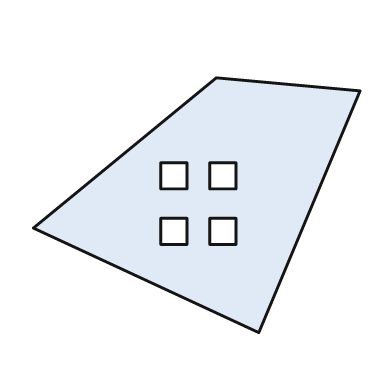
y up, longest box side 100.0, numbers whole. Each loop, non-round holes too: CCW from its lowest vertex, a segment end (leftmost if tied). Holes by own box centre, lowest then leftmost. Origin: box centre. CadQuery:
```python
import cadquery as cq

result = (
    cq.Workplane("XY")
    .moveTo(19.0, -39.0)
    .lineTo(50.0, 35.0)
    .lineTo(6.0, 39.0)
    .lineTo(-50.0, -7.0)
    .close()
    .moveTo(-11.0, -12.0)
    .lineTo(-3.0, -12.0)
    .lineTo(-3.0, -4.0)
    .lineTo(-11.0, -4.0)
    .close()
    .moveTo(4.0, -12.0)
    .lineTo(12.0, -12.0)
    .lineTo(12.0, -4.0)
    .lineTo(4.0, -4.0)
    .close()
    .moveTo(-11.0, 5.0)
    .lineTo(-3.0, 5.0)
    .lineTo(-3.0, 13.0)
    .lineTo(-11.0, 13.0)
    .close()
    .moveTo(4.0, 5.0)
    .lineTo(12.0, 5.0)
    .lineTo(12.0, 13.0)
    .lineTo(4.0, 13.0)
    .close()
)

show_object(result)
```